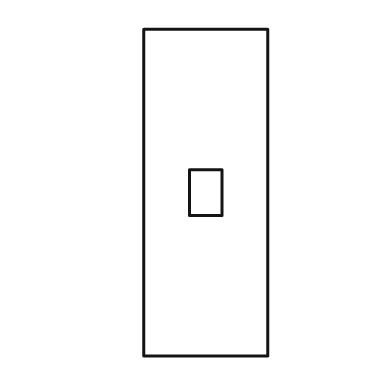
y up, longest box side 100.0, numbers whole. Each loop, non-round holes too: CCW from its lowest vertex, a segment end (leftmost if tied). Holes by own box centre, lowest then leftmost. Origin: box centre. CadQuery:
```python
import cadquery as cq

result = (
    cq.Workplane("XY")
    .moveTo(-19.0, -50.0)
    .lineTo(19.0, -50.0)
    .lineTo(19.0, 50.0)
    .lineTo(-19.0, 50.0)
    .close()
    .moveTo(-5.0, -7.0)
    .lineTo(5.0, -7.0)
    .lineTo(5.0, 7.0)
    .lineTo(-5.0, 7.0)
    .close()
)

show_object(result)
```